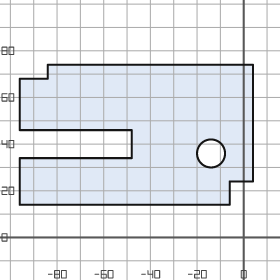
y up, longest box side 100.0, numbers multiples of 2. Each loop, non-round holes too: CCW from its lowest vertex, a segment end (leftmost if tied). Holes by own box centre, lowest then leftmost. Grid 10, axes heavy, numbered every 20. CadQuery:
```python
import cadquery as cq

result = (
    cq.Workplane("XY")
    .moveTo(-96.0, 14.0)
    .lineTo(-6.0, 14.0)
    .lineTo(-6.0, 24.0)
    .lineTo(4.0, 24.0)
    .lineTo(4.0, 74.0)
    .lineTo(-84.0, 74.0)
    .lineTo(-84.0, 68.0)
    .lineTo(-96.0, 68.0)
    .lineTo(-96.0, 46.0)
    .lineTo(-48.0, 46.0)
    .lineTo(-48.0, 34.0)
    .lineTo(-96.0, 34.0)
    .close()
    .moveTo(-14.0, 36.0)
    .circle(6.0)
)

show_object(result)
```